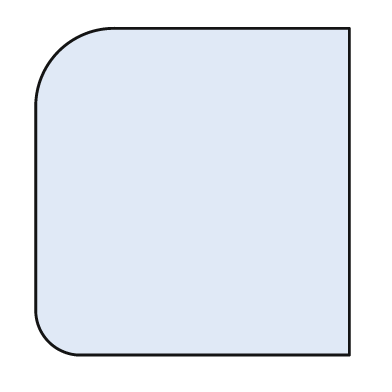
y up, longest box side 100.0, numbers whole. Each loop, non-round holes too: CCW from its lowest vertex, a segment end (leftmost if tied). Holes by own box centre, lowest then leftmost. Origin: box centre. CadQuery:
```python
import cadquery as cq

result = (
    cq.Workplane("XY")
    .moveTo(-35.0, -50.0)
    .lineTo(48.0, -50.0)
    .lineTo(48.0, 50.0)
    .lineTo(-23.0, 50.0)
    .threePointArc((-41.0, 43.0), (-48.0, 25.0))
    .lineTo(-48.0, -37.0)
    .threePointArc((-44.0, -46.0), (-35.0, -50.0))
    .close()
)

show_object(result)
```